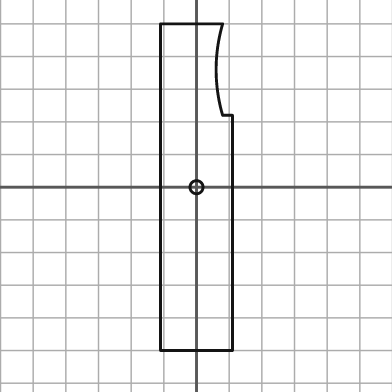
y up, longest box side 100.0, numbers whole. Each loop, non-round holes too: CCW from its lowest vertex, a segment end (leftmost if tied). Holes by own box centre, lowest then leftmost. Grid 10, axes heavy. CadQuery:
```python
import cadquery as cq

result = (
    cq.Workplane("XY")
    .moveTo(-11.0, -50.0)
    .lineTo(11.0, -50.0)
    .lineTo(11.0, 22.0)
    .lineTo(8.0, 22.0)
    .threePointArc((6.0, 36.0), (8.0, 50.0))
    .lineTo(-11.0, 50.0)
    .close()
    .moveTo(0.0, 0.0)
    .circle(2.0)
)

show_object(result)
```